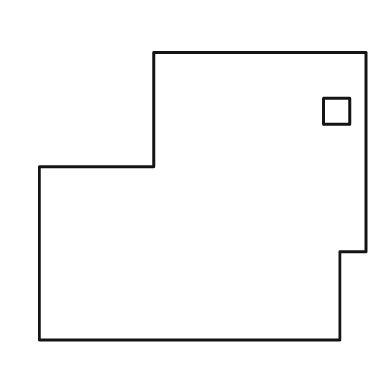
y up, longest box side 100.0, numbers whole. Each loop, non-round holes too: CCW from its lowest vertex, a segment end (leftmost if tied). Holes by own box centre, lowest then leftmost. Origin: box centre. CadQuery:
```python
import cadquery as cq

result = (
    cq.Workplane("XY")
    .moveTo(-50.0, -44.0)
    .lineTo(42.0, -44.0)
    .lineTo(42.0, -17.0)
    .lineTo(50.0, -17.0)
    .lineTo(50.0, 44.0)
    .lineTo(-15.0, 44.0)
    .lineTo(-15.0, 9.0)
    .lineTo(-50.0, 9.0)
    .close()
    .moveTo(37.0, 22.0)
    .lineTo(45.0, 22.0)
    .lineTo(45.0, 30.0)
    .lineTo(37.0, 30.0)
    .close()
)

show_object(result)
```